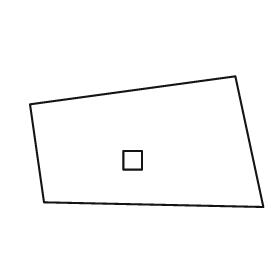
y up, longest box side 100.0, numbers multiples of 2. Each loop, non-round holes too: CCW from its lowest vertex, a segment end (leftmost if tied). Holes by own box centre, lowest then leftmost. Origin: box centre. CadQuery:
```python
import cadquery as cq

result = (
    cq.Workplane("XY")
    .moveTo(50.0, -28.0)
    .lineTo(38.0, 28.0)
    .lineTo(-50.0, 16.0)
    .lineTo(-44.0, -26.0)
    .close()
    .moveTo(-10.0, -12.0)
    .lineTo(-2.0, -12.0)
    .lineTo(-2.0, -4.0)
    .lineTo(-10.0, -4.0)
    .close()
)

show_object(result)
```